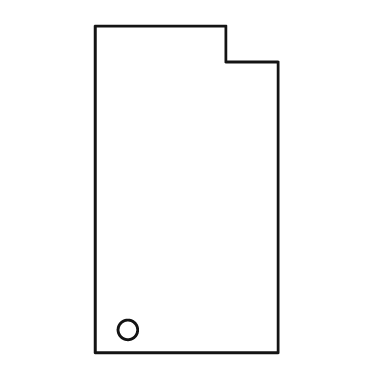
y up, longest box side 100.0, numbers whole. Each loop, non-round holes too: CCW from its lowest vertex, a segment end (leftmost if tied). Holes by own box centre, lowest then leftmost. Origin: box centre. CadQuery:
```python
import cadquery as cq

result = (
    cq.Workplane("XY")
    .moveTo(-28.0, -50.0)
    .lineTo(28.0, -50.0)
    .lineTo(28.0, 39.0)
    .lineTo(12.0, 39.0)
    .lineTo(12.0, 50.0)
    .lineTo(-28.0, 50.0)
    .close()
    .moveTo(-18.0, -43.0)
    .circle(3.0)
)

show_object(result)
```